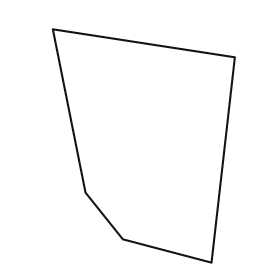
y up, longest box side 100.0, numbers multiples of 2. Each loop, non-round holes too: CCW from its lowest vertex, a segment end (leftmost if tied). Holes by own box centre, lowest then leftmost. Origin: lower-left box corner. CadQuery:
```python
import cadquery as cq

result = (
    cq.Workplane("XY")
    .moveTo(68.0, 0.0)
    .lineTo(78.0, 88.0)
    .lineTo(0.0, 100.0)
    .lineTo(14.0, 30.0)
    .lineTo(30.0, 10.0)
    .close()
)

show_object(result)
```